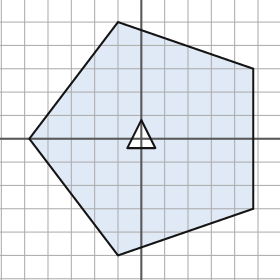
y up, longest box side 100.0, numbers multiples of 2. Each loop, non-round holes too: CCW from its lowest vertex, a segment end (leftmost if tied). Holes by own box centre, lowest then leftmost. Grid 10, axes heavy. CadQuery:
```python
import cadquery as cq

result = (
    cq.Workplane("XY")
    .moveTo(-10.0, -50.0)
    .lineTo(48.0, -30.0)
    .lineTo(48.0, 30.0)
    .lineTo(-10.0, 50.0)
    .lineTo(-48.0, 0.0)
    .close()
    .moveTo(-6.0, -4.0)
    .lineTo(6.0, -4.0)
    .lineTo(0.0, 8.0)
    .close()
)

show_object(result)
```